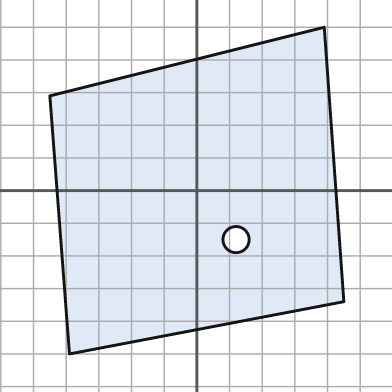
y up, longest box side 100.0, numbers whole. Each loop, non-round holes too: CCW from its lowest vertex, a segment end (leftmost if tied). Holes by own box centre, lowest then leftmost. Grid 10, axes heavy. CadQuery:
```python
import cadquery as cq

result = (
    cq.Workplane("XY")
    .moveTo(-39.0, -50.0)
    .lineTo(45.0, -34.0)
    .lineTo(39.0, 50.0)
    .lineTo(-45.0, 29.0)
    .close()
    .moveTo(12.0, -15.0)
    .circle(4.0)
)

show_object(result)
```